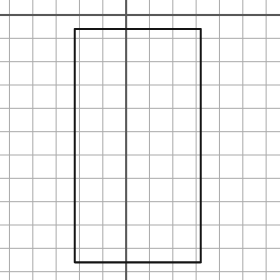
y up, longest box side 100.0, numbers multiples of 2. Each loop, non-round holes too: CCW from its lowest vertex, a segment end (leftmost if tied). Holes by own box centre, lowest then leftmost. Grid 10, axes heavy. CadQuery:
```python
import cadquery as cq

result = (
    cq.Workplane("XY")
    .moveTo(-22.0, -106.0)
    .lineTo(32.0, -106.0)
    .lineTo(32.0, -6.0)
    .lineTo(-22.0, -6.0)
    .close()
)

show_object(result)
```